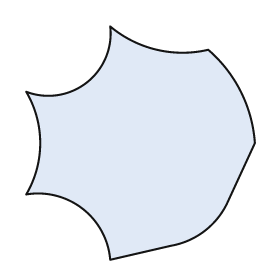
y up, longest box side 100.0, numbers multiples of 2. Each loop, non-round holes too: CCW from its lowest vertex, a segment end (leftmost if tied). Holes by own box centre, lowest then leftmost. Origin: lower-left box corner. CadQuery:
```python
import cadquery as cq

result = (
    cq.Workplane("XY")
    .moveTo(36.0, 0.0)
    .lineTo(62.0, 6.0)
    .threePointArc((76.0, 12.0), (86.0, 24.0))
    .lineTo(98.0, 50.0)
    .threePointArc((92.0, 72.0), (78.0, 90.0))
    .threePointArc((56.0, 90.0), (36.0, 100.0))
    .threePointArc((26.0, 76.0), (0.0, 72.0))
    .threePointArc((6.0, 50.0), (0.0, 28.0))
    .threePointArc((24.0, 22.0), (36.0, 0.0))
    .close()
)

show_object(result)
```